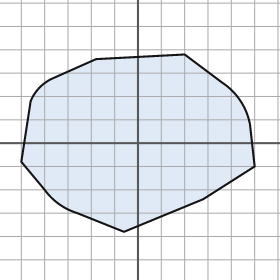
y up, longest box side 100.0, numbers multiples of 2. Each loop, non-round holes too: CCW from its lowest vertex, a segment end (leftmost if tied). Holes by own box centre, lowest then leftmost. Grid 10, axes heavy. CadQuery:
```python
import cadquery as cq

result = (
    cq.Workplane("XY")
    .moveTo(-6.0, -38.0)
    .lineTo(28.0, -24.0)
    .lineTo(50.0, -10.0)
    .lineTo(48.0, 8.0)
    .threePointArc((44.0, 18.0), (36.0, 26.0))
    .lineTo(20.0, 38.0)
    .lineTo(-18.0, 36.0)
    .lineTo(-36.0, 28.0)
    .threePointArc((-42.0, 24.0), (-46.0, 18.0))
    .lineTo(-50.0, -8.0)
    .lineTo(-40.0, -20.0)
    .threePointArc((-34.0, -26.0), (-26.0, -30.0))
    .close()
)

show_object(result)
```